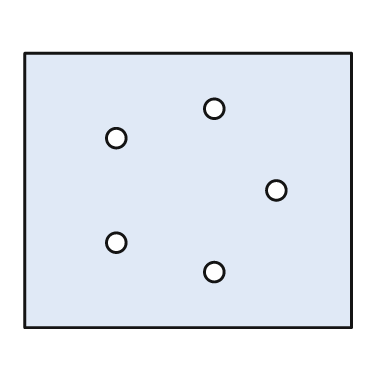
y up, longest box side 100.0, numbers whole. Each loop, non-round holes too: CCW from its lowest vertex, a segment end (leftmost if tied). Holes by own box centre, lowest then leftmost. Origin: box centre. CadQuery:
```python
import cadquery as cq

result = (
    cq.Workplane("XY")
    .moveTo(-50.0, -42.0)
    .lineTo(50.0, -42.0)
    .lineTo(50.0, 42.0)
    .lineTo(-50.0, 42.0)
    .close()
    .moveTo(8.0, -25.0)
    .circle(3.0)
    .moveTo(-22.0, -16.0)
    .circle(3.0)
    .moveTo(27.0, 0.0)
    .circle(3.0)
    .moveTo(-22.0, 16.0)
    .circle(3.0)
    .moveTo(8.0, 25.0)
    .circle(3.0)
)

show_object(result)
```